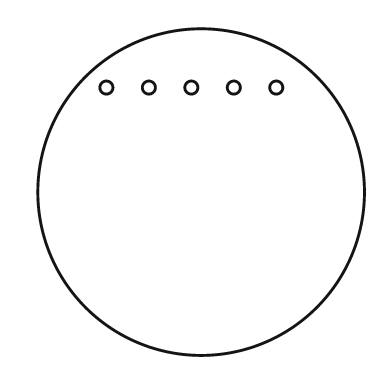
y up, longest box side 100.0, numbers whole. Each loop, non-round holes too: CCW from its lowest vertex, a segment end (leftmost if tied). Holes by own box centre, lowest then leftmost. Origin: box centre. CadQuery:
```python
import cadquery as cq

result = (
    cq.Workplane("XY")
    .moveTo(0.0, 0.0)
    .circle(50.0)
    .moveTo(-29.0, 32.0)
    .circle(2.0)
    .moveTo(-16.0, 32.0)
    .circle(2.0)
    .moveTo(-3.0, 32.0)
    .circle(2.0)
    .moveTo(10.0, 32.0)
    .circle(2.0)
    .moveTo(23.0, 32.0)
    .circle(2.0)
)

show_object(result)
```